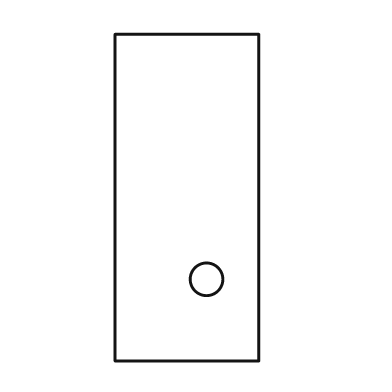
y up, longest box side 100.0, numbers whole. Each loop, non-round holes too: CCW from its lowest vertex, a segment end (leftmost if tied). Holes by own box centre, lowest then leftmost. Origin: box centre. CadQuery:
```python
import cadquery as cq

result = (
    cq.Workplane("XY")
    .moveTo(-22.0, -50.0)
    .lineTo(22.0, -50.0)
    .lineTo(22.0, 50.0)
    .lineTo(-22.0, 50.0)
    .close()
    .moveTo(6.0, -25.0)
    .circle(5.0)
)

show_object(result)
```